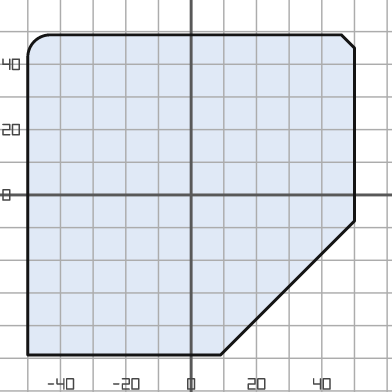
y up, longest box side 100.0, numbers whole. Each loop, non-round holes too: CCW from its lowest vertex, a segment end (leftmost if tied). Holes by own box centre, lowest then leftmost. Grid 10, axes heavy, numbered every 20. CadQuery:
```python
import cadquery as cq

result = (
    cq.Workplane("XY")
    .moveTo(-50.0, -49.0)
    .lineTo(9.0, -49.0)
    .lineTo(50.0, -8.0)
    .lineTo(50.0, 45.0)
    .lineTo(46.0, 49.0)
    .lineTo(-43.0, 49.0)
    .threePointArc((-48.0, 47.0), (-50.0, 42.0))
    .close()
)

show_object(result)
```